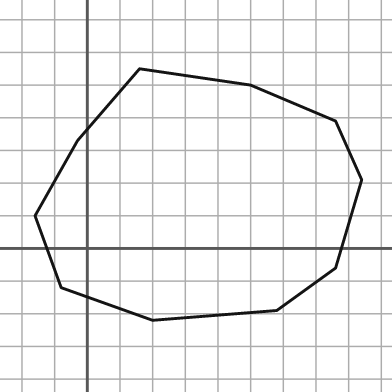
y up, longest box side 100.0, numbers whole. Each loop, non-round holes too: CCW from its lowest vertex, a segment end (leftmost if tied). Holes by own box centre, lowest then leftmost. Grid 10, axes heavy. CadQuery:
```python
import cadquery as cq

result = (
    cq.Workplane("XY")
    .moveTo(20.0, -22.0)
    .lineTo(58.0, -19.0)
    .lineTo(76.0, -6.0)
    .lineTo(84.0, 21.0)
    .lineTo(76.0, 39.0)
    .lineTo(50.0, 50.0)
    .lineTo(16.0, 55.0)
    .lineTo(-3.0, 33.0)
    .lineTo(-16.0, 10.0)
    .lineTo(-8.0, -12.0)
    .close()
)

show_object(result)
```